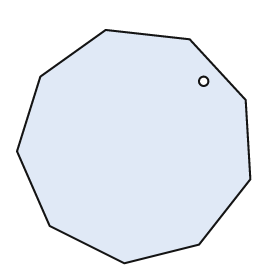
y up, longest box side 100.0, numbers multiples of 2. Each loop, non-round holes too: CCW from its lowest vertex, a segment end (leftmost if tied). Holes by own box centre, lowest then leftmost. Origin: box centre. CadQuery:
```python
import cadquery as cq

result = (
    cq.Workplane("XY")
    .moveTo(-4.0, -50.0)
    .lineTo(28.0, -42.0)
    .lineTo(50.0, -14.0)
    .lineTo(48.0, 20.0)
    .lineTo(24.0, 46.0)
    .lineTo(-12.0, 50.0)
    .lineTo(-40.0, 30.0)
    .lineTo(-50.0, -2.0)
    .lineTo(-36.0, -34.0)
    .close()
    .moveTo(30.0, 28.0)
    .circle(2.0)
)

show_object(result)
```